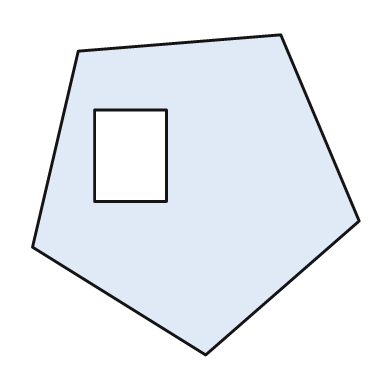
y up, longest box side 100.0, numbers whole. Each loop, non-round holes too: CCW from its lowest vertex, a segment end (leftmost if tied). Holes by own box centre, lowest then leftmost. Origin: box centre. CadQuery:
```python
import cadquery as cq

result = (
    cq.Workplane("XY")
    .moveTo(3.0, -49.0)
    .lineTo(50.0, -8.0)
    .lineTo(26.0, 49.0)
    .lineTo(-36.0, 44.0)
    .lineTo(-50.0, -16.0)
    .close()
    .moveTo(-31.0, -2.0)
    .lineTo(-9.0, -2.0)
    .lineTo(-9.0, 26.0)
    .lineTo(-31.0, 26.0)
    .close()
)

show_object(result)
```